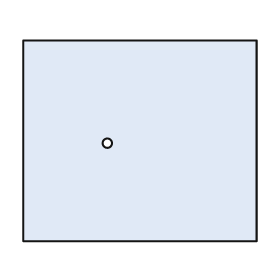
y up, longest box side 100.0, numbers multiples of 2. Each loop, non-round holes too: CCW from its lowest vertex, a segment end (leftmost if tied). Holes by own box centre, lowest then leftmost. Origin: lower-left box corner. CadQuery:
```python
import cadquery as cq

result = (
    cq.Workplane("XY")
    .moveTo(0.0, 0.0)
    .lineTo(100.0, 0.0)
    .lineTo(100.0, 86.0)
    .lineTo(0.0, 86.0)
    .close()
    .moveTo(36.0, 42.0)
    .circle(2.0)
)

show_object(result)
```